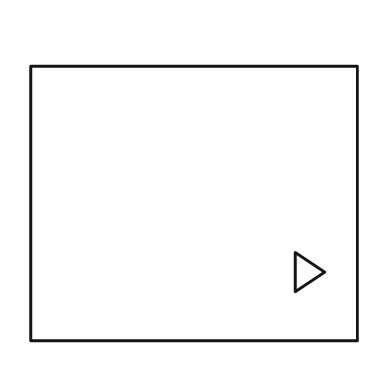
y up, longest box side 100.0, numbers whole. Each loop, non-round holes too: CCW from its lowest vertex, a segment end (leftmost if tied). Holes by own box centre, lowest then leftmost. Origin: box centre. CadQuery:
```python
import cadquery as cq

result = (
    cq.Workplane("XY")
    .moveTo(-50.0, -42.0)
    .lineTo(50.0, -42.0)
    .lineTo(50.0, 42.0)
    .lineTo(-50.0, 42.0)
    .close()
    .moveTo(31.0, -27.0)
    .lineTo(40.0, -21.0)
    .lineTo(31.0, -15.0)
    .close()
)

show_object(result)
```